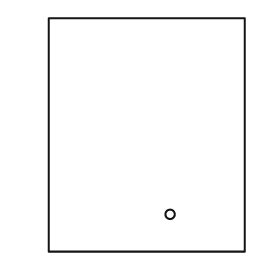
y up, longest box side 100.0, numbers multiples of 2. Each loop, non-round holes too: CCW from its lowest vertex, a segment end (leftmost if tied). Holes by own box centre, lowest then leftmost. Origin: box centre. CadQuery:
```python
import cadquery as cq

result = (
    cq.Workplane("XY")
    .moveTo(-42.0, -50.0)
    .lineTo(42.0, -50.0)
    .lineTo(42.0, 50.0)
    .lineTo(-42.0, 50.0)
    .close()
    .moveTo(10.0, -34.0)
    .circle(2.0)
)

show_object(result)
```